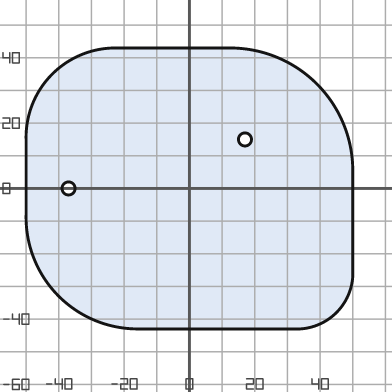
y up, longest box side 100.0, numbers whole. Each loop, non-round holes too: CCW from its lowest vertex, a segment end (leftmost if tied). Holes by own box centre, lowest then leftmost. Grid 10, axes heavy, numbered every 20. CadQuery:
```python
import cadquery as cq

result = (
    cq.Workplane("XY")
    .moveTo(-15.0, -43.0)
    .lineTo(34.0, -43.0)
    .threePointArc((45.0, -38.0), (50.0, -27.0))
    .lineTo(50.0, 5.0)
    .threePointArc((39.0, 32.0), (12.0, 43.0))
    .lineTo(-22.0, 43.0)
    .threePointArc((-42.0, 35.0), (-50.0, 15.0))
    .lineTo(-50.0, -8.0)
    .threePointArc((-40.0, -33.0), (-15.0, -43.0))
    .close()
    .moveTo(-37.0, 0.0)
    .circle(2.0)
    .moveTo(17.0, 15.0)
    .circle(2.0)
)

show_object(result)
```